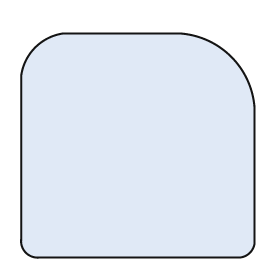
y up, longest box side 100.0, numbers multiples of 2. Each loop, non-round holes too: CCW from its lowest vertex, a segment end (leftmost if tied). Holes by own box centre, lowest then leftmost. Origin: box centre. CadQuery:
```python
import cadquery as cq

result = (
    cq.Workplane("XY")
    .moveTo(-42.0, -48.0)
    .lineTo(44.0, -48.0)
    .threePointArc((48.0, -46.0), (50.0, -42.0))
    .lineTo(50.0, 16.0)
    .threePointArc((40.0, 38.0), (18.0, 48.0))
    .lineTo(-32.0, 48.0)
    .threePointArc((-44.0, 42.0), (-50.0, 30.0))
    .lineTo(-50.0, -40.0)
    .threePointArc((-48.0, -46.0), (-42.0, -48.0))
    .close()
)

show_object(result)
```